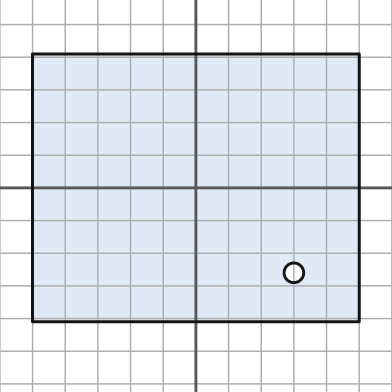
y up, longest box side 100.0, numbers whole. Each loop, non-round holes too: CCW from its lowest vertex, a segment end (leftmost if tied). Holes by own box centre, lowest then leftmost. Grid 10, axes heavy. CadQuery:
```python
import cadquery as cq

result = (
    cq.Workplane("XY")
    .moveTo(-50.0, -41.0)
    .lineTo(50.0, -41.0)
    .lineTo(50.0, 41.0)
    .lineTo(-50.0, 41.0)
    .close()
    .moveTo(30.0, -26.0)
    .circle(3.0)
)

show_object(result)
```